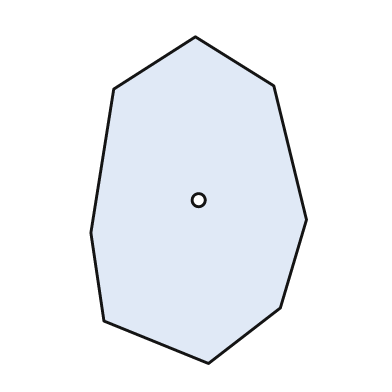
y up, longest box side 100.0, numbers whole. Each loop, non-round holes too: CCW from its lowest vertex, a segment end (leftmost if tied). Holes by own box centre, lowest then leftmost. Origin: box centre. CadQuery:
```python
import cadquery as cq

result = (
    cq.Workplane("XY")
    .moveTo(3.0, -50.0)
    .lineTo(25.0, -33.0)
    .lineTo(33.0, -6.0)
    .lineTo(23.0, 35.0)
    .lineTo(-1.0, 50.0)
    .lineTo(-26.0, 34.0)
    .lineTo(-33.0, -10.0)
    .lineTo(-29.0, -37.0)
    .close()
    .moveTo(0.0, 0.0)
    .circle(2.0)
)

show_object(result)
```